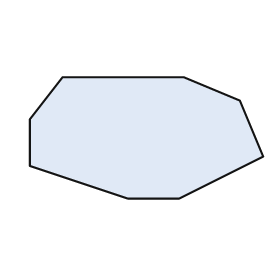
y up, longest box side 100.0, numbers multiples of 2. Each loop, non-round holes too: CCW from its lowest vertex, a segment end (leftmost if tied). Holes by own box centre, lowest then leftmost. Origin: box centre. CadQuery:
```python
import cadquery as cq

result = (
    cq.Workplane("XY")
    .moveTo(-8.0, -26.0)
    .lineTo(14.0, -26.0)
    .lineTo(50.0, -8.0)
    .lineTo(40.0, 16.0)
    .lineTo(16.0, 26.0)
    .lineTo(-36.0, 26.0)
    .lineTo(-50.0, 8.0)
    .lineTo(-50.0, -12.0)
    .close()
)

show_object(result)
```